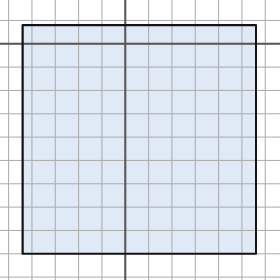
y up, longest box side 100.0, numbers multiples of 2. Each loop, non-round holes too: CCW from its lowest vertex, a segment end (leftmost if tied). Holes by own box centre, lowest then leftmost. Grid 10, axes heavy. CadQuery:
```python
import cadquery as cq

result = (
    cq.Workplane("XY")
    .moveTo(-44.0, -90.0)
    .lineTo(56.0, -90.0)
    .lineTo(56.0, 8.0)
    .lineTo(-44.0, 8.0)
    .close()
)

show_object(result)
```